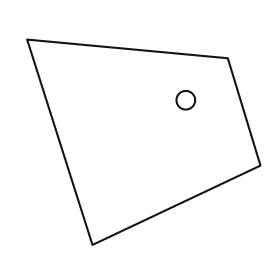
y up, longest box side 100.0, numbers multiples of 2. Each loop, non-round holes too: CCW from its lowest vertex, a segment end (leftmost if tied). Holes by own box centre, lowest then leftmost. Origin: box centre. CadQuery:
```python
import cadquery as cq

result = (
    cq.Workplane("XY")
    .moveTo(-22.0, -44.0)
    .lineTo(50.0, -10.0)
    .lineTo(36.0, 36.0)
    .lineTo(-50.0, 44.0)
    .close()
    .moveTo(18.0, 18.0)
    .circle(4.0)
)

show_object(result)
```